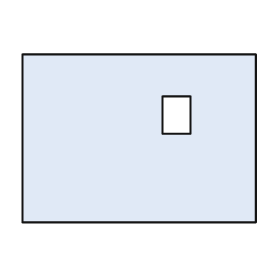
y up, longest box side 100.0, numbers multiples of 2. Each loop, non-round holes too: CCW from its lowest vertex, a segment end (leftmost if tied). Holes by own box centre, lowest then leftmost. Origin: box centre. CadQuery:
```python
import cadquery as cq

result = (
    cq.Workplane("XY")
    .moveTo(-50.0, -36.0)
    .lineTo(50.0, -36.0)
    .lineTo(50.0, 36.0)
    .lineTo(-50.0, 36.0)
    .close()
    .moveTo(10.0, 2.0)
    .lineTo(22.0, 2.0)
    .lineTo(22.0, 18.0)
    .lineTo(10.0, 18.0)
    .close()
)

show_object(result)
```